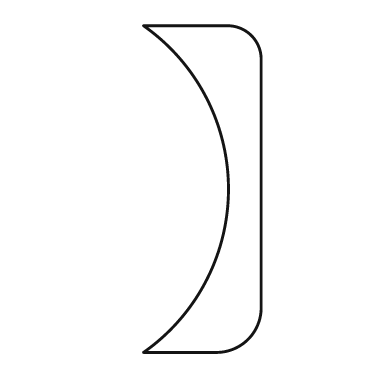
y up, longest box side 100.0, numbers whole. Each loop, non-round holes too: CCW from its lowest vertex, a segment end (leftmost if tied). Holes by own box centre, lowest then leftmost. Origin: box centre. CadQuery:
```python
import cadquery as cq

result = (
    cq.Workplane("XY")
    .moveTo(-18.0, -50.0)
    .lineTo(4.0, -50.0)
    .threePointArc((14.0, -46.0), (18.0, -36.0))
    .lineTo(18.0, 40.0)
    .threePointArc((15.0, 47.0), (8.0, 50.0))
    .lineTo(-18.0, 50.0)
    .threePointArc((8.0, 0.0), (-18.0, -50.0))
    .close()
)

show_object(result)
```